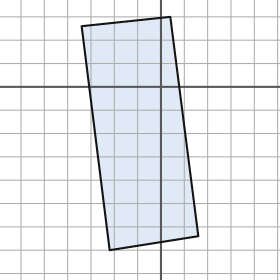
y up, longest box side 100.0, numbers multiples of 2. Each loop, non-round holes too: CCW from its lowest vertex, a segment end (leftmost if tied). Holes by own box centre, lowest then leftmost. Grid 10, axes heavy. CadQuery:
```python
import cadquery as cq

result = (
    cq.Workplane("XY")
    .moveTo(-22.0, -70.0)
    .lineTo(16.0, -64.0)
    .lineTo(4.0, 30.0)
    .lineTo(-34.0, 26.0)
    .close()
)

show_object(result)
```